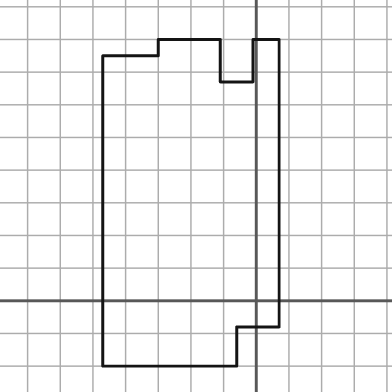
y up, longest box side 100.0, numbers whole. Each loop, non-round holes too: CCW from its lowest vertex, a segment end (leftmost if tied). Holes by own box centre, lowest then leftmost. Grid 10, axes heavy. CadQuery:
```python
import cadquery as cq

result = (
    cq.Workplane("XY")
    .moveTo(-47.0, -20.0)
    .lineTo(-6.0, -20.0)
    .lineTo(-6.0, -8.0)
    .lineTo(7.0, -8.0)
    .lineTo(7.0, 80.0)
    .lineTo(-1.0, 80.0)
    .lineTo(-1.0, 67.0)
    .lineTo(-11.0, 67.0)
    .lineTo(-11.0, 80.0)
    .lineTo(-30.0, 80.0)
    .lineTo(-30.0, 75.0)
    .lineTo(-47.0, 75.0)
    .close()
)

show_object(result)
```